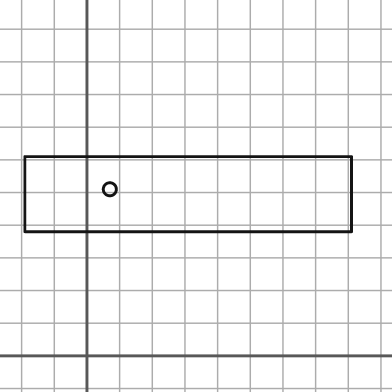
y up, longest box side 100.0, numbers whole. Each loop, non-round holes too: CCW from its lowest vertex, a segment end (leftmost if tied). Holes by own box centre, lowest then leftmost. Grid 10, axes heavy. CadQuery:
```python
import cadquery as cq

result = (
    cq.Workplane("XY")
    .moveTo(-19.0, 38.0)
    .lineTo(81.0, 38.0)
    .lineTo(81.0, 61.0)
    .lineTo(-19.0, 61.0)
    .close()
    .moveTo(7.0, 51.0)
    .circle(2.0)
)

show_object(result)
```